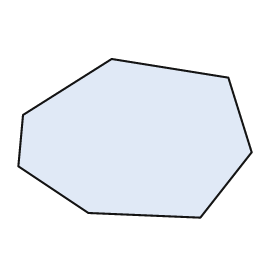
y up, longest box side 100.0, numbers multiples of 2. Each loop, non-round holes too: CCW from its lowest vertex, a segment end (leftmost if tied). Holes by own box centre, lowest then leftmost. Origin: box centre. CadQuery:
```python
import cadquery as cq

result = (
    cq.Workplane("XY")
    .moveTo(28.0, -34.0)
    .lineTo(50.0, -6.0)
    .lineTo(40.0, 26.0)
    .lineTo(-10.0, 34.0)
    .lineTo(-48.0, 10.0)
    .lineTo(-50.0, -12.0)
    .lineTo(-20.0, -32.0)
    .close()
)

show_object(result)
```